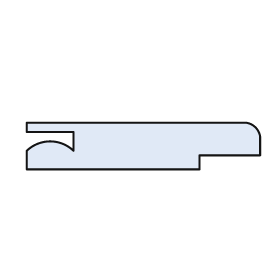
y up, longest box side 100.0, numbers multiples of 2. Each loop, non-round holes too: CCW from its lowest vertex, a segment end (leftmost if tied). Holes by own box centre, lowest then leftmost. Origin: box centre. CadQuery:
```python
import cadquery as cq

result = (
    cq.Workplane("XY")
    .moveTo(-50.0, -10.0)
    .lineTo(24.0, -10.0)
    .lineTo(24.0, -4.0)
    .lineTo(50.0, -4.0)
    .lineTo(50.0, 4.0)
    .threePointArc((48.0, 8.0), (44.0, 10.0))
    .lineTo(-50.0, 10.0)
    .lineTo(-50.0, 6.0)
    .lineTo(-30.0, 6.0)
    .lineTo(-30.0, -2.0)
    .threePointArc((-40.0, 2.0), (-50.0, -2.0))
    .close()
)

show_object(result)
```